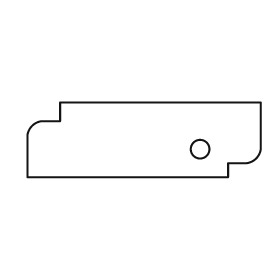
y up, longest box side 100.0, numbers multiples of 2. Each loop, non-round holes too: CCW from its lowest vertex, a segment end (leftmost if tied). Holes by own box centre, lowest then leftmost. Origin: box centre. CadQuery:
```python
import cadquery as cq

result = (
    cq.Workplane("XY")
    .moveTo(-50.0, -16.0)
    .lineTo(36.0, -16.0)
    .lineTo(36.0, -10.0)
    .lineTo(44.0, -10.0)
    .threePointArc((48.0, -8.0), (50.0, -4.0))
    .lineTo(50.0, 16.0)
    .lineTo(-36.0, 16.0)
    .lineTo(-36.0, 8.0)
    .lineTo(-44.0, 8.0)
    .threePointArc((-48.0, 6.0), (-50.0, 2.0))
    .close()
    .moveTo(24.0, -4.0)
    .circle(4.0)
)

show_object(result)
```